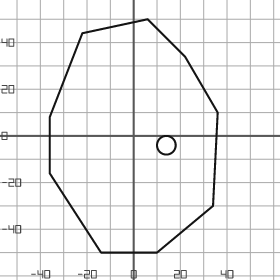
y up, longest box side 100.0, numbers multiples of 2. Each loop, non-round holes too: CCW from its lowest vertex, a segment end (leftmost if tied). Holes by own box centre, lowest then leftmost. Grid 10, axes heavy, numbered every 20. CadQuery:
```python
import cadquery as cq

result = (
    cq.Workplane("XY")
    .moveTo(-14.0, -50.0)
    .lineTo(10.0, -50.0)
    .lineTo(34.0, -30.0)
    .lineTo(36.0, 10.0)
    .lineTo(22.0, 34.0)
    .lineTo(6.0, 50.0)
    .lineTo(-22.0, 44.0)
    .lineTo(-36.0, 8.0)
    .lineTo(-36.0, -16.0)
    .close()
    .moveTo(14.0, -4.0)
    .circle(4.0)
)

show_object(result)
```